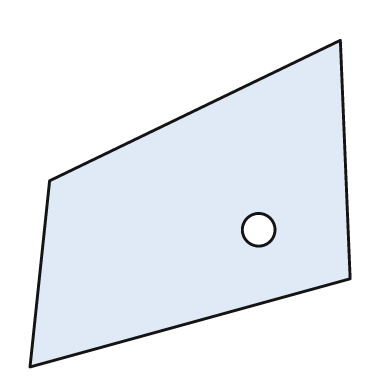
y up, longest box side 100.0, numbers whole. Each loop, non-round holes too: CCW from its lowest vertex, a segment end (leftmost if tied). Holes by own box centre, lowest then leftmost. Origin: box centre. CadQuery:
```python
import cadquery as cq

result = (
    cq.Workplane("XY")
    .moveTo(-49.0, -50.0)
    .lineTo(49.0, -23.0)
    .lineTo(46.0, 50.0)
    .lineTo(-43.0, 7.0)
    .close()
    .moveTo(21.0, -8.0)
    .circle(5.0)
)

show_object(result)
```